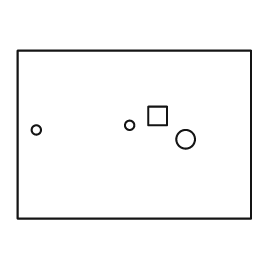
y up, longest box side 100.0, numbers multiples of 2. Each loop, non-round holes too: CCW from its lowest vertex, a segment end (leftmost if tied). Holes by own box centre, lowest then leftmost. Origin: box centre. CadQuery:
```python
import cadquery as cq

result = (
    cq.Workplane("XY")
    .moveTo(-50.0, -36.0)
    .lineTo(50.0, -36.0)
    .lineTo(50.0, 36.0)
    .lineTo(-50.0, 36.0)
    .close()
    .moveTo(22.0, -2.0)
    .circle(4.0)
    .moveTo(-42.0, 2.0)
    .circle(2.0)
    .moveTo(-2.0, 4.0)
    .circle(2.0)
    .moveTo(6.0, 4.0)
    .lineTo(14.0, 4.0)
    .lineTo(14.0, 12.0)
    .lineTo(6.0, 12.0)
    .close()
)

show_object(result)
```